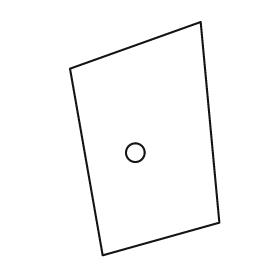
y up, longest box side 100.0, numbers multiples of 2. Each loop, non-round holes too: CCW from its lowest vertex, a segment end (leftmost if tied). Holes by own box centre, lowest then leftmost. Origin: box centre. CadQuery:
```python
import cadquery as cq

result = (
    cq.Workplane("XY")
    .moveTo(-18.0, -50.0)
    .lineTo(32.0, -36.0)
    .lineTo(24.0, 50.0)
    .lineTo(-32.0, 30.0)
    .close()
    .moveTo(-4.0, -6.0)
    .circle(4.0)
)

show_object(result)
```